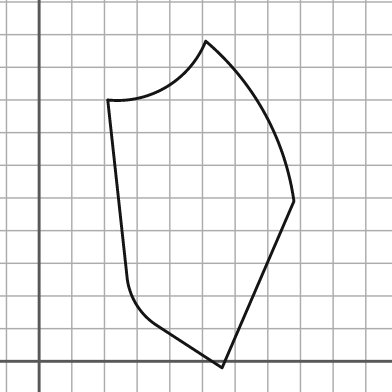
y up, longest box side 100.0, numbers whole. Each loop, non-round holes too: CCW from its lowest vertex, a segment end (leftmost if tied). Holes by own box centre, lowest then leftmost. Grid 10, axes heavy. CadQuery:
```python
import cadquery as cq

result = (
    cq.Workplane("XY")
    .moveTo(56.0, -2.0)
    .lineTo(78.0, 49.0)
    .threePointArc((69.0, 76.0), (51.0, 98.0))
    .threePointArc((39.0, 84.0), (21.0, 80.0))
    .lineTo(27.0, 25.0)
    .threePointArc((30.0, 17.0), (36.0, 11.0))
    .close()
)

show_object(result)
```